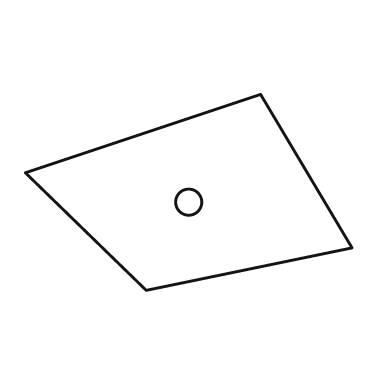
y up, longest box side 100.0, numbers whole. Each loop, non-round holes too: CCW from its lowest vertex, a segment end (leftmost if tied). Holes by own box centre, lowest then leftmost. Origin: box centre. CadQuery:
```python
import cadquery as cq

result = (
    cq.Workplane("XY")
    .moveTo(-13.0, -30.0)
    .lineTo(50.0, -17.0)
    .lineTo(22.0, 30.0)
    .lineTo(-50.0, 6.0)
    .close()
    .moveTo(0.0, -3.0)
    .circle(4.0)
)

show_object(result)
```